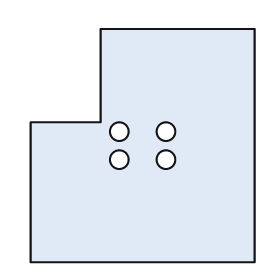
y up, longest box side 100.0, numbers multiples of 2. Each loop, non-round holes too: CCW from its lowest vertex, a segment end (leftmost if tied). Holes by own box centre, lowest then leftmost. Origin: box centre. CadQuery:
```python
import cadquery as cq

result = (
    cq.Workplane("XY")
    .moveTo(-48.0, -50.0)
    .lineTo(48.0, -50.0)
    .lineTo(48.0, 50.0)
    .lineTo(-18.0, 50.0)
    .lineTo(-18.0, 10.0)
    .lineTo(-48.0, 10.0)
    .close()
    .moveTo(-10.0, -6.0)
    .circle(4.0)
    .moveTo(10.0, -6.0)
    .circle(4.0)
    .moveTo(-10.0, 6.0)
    .circle(4.0)
    .moveTo(10.0, 6.0)
    .circle(4.0)
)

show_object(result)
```